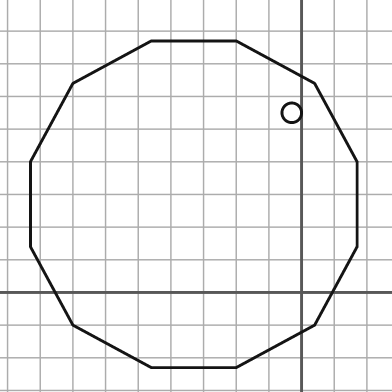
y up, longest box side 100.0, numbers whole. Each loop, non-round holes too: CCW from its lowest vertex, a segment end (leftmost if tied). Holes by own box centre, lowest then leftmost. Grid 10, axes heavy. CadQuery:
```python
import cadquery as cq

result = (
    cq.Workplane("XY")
    .moveTo(-46.0, -23.0)
    .lineTo(-20.0, -23.0)
    .lineTo(4.0, -10.0)
    .lineTo(17.0, 14.0)
    .lineTo(17.0, 40.0)
    .lineTo(4.0, 64.0)
    .lineTo(-20.0, 77.0)
    .lineTo(-46.0, 77.0)
    .lineTo(-70.0, 64.0)
    .lineTo(-83.0, 40.0)
    .lineTo(-83.0, 14.0)
    .lineTo(-70.0, -10.0)
    .close()
    .moveTo(-3.0, 55.0)
    .circle(3.0)
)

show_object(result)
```